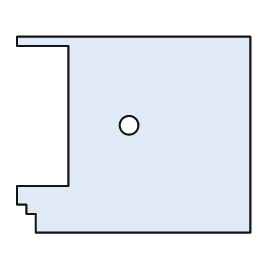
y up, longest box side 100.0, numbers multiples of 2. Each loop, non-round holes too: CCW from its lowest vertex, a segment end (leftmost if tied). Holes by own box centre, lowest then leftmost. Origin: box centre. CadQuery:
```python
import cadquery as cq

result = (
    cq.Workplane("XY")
    .moveTo(-42.0, -42.0)
    .lineTo(50.0, -42.0)
    .lineTo(50.0, 42.0)
    .lineTo(-50.0, 42.0)
    .lineTo(-50.0, 38.0)
    .lineTo(-28.0, 38.0)
    .lineTo(-28.0, -22.0)
    .lineTo(-50.0, -22.0)
    .lineTo(-50.0, -30.0)
    .lineTo(-46.0, -30.0)
    .lineTo(-46.0, -34.0)
    .lineTo(-42.0, -34.0)
    .close()
    .moveTo(-2.0, 4.0)
    .circle(4.0)
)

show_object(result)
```